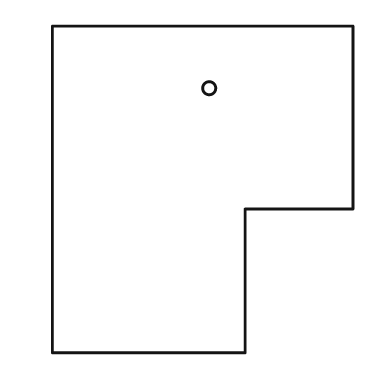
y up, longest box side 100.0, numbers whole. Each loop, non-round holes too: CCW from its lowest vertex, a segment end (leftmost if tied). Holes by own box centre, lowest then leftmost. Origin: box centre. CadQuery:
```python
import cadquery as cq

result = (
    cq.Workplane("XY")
    .moveTo(-46.0, -50.0)
    .lineTo(13.0, -50.0)
    .lineTo(13.0, -6.0)
    .lineTo(46.0, -6.0)
    .lineTo(46.0, 50.0)
    .lineTo(-46.0, 50.0)
    .close()
    .moveTo(2.0, 31.0)
    .circle(2.0)
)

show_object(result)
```